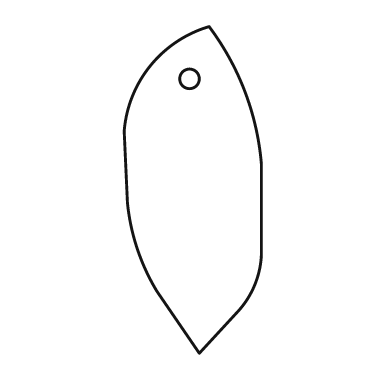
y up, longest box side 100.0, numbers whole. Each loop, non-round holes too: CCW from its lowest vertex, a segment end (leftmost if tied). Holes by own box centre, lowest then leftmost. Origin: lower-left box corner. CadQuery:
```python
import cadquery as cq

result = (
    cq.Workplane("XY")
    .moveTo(23.0, 0.0)
    .lineTo(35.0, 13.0)
    .threePointArc((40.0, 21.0), (42.0, 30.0))
    .lineTo(42.0, 58.0)
    .threePointArc((37.0, 80.0), (26.0, 100.0))
    .threePointArc((8.0, 88.0), (0.0, 68.0))
    .lineTo(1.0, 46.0)
    .threePointArc((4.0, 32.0), (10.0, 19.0))
    .close()
    .moveTo(20.0, 84.0)
    .circle(3.0)
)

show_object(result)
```